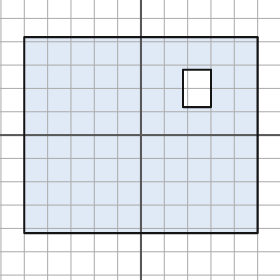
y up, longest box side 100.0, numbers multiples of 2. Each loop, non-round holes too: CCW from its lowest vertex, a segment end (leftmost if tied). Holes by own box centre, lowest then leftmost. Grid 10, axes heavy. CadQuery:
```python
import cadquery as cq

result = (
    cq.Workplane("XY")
    .moveTo(-50.0, -42.0)
    .lineTo(50.0, -42.0)
    .lineTo(50.0, 42.0)
    .lineTo(-50.0, 42.0)
    .close()
    .moveTo(18.0, 12.0)
    .lineTo(30.0, 12.0)
    .lineTo(30.0, 28.0)
    .lineTo(18.0, 28.0)
    .close()
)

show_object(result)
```